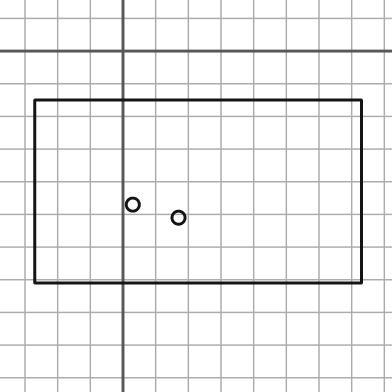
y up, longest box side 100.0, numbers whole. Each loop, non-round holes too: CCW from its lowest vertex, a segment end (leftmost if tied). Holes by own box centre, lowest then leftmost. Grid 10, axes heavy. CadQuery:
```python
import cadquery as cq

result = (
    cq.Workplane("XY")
    .moveTo(-27.0, -71.0)
    .lineTo(73.0, -71.0)
    .lineTo(73.0, -15.0)
    .lineTo(-27.0, -15.0)
    .close()
    .moveTo(17.0, -51.0)
    .circle(2.0)
    .moveTo(3.0, -47.0)
    .circle(2.0)
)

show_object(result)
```